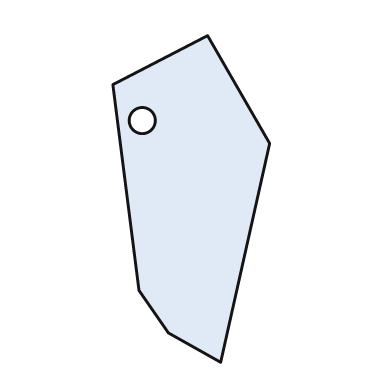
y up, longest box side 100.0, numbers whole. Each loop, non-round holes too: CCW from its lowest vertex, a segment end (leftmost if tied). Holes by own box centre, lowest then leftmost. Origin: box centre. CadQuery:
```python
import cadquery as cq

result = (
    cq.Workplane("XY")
    .moveTo(9.0, -50.0)
    .lineTo(24.0, 17.0)
    .lineTo(5.0, 50.0)
    .lineTo(-24.0, 35.0)
    .lineTo(-16.0, -28.0)
    .lineTo(-7.0, -41.0)
    .close()
    .moveTo(-15.0, 24.0)
    .circle(4.0)
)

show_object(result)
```